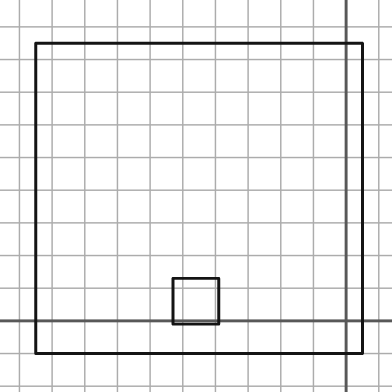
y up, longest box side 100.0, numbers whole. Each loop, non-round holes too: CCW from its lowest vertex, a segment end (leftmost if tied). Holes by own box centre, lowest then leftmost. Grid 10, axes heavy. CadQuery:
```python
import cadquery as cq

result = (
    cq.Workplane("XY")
    .moveTo(-95.0, -10.0)
    .lineTo(5.0, -10.0)
    .lineTo(5.0, 85.0)
    .lineTo(-95.0, 85.0)
    .close()
    .moveTo(-53.0, -1.0)
    .lineTo(-39.0, -1.0)
    .lineTo(-39.0, 13.0)
    .lineTo(-53.0, 13.0)
    .close()
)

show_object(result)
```